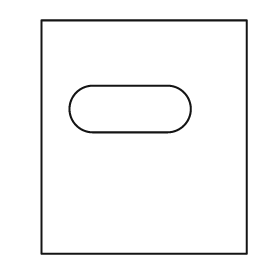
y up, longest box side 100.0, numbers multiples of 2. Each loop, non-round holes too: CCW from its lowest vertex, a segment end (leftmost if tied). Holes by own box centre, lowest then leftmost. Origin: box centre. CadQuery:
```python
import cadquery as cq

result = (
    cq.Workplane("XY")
    .moveTo(-44.0, -50.0)
    .lineTo(44.0, -50.0)
    .lineTo(44.0, 50.0)
    .lineTo(-44.0, 50.0)
    .close()
    .moveTo(-22.0, 2.0)
    .lineTo(10.0, 2.0)
    .threePointArc((20.0, 12.0), (10.0, 22.0))
    .lineTo(-22.0, 22.0)
    .threePointArc((-32.0, 12.0), (-22.0, 2.0))
    .close()
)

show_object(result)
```